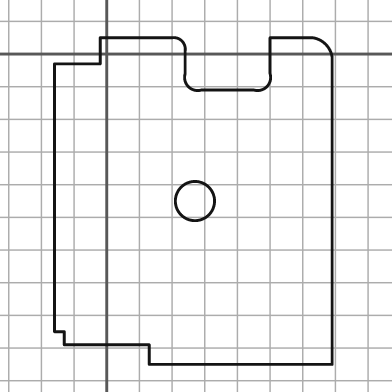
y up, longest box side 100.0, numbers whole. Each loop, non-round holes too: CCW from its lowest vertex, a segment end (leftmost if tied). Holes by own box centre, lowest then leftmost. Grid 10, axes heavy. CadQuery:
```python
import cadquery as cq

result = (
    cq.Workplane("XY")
    .moveTo(13.0, -95.0)
    .lineTo(69.0, -95.0)
    .lineTo(69.0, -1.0)
    .threePointArc((67.0, 3.0), (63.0, 5.0))
    .lineTo(50.0, 5.0)
    .lineTo(50.0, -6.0)
    .threePointArc((49.0, -10.0), (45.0, -11.0))
    .lineTo(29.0, -11.0)
    .threePointArc((25.0, -10.0), (24.0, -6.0))
    .lineTo(24.0, 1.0)
    .threePointArc((23.0, 4.0), (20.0, 5.0))
    .lineTo(-2.0, 5.0)
    .lineTo(-2.0, -3.0)
    .lineTo(-16.0, -3.0)
    .lineTo(-16.0, -85.0)
    .lineTo(-13.0, -85.0)
    .lineTo(-13.0, -89.0)
    .lineTo(13.0, -89.0)
    .close()
    .moveTo(27.0, -45.0)
    .circle(6.0)
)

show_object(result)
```